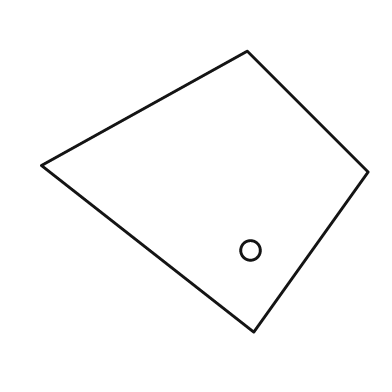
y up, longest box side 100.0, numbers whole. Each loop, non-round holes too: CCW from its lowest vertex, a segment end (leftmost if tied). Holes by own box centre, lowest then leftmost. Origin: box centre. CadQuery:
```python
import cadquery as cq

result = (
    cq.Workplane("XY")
    .moveTo(15.0, -43.0)
    .lineTo(50.0, 6.0)
    .lineTo(13.0, 43.0)
    .lineTo(-50.0, 8.0)
    .close()
    .moveTo(14.0, -18.0)
    .circle(3.0)
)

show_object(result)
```